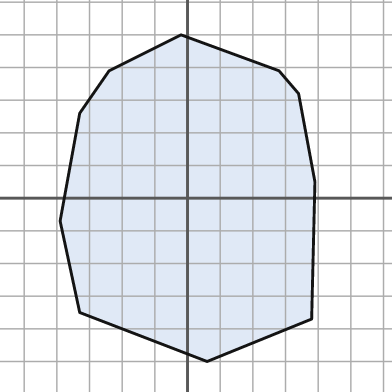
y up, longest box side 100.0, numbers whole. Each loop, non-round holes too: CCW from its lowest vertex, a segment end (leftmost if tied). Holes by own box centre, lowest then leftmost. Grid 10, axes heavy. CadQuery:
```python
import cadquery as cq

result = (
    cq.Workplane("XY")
    .moveTo(6.0, -50.0)
    .lineTo(38.0, -37.0)
    .lineTo(39.0, 5.0)
    .lineTo(34.0, 32.0)
    .lineTo(28.0, 39.0)
    .lineTo(-2.0, 50.0)
    .lineTo(-24.0, 39.0)
    .lineTo(-33.0, 26.0)
    .lineTo(-39.0, -7.0)
    .lineTo(-33.0, -35.0)
    .close()
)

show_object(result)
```